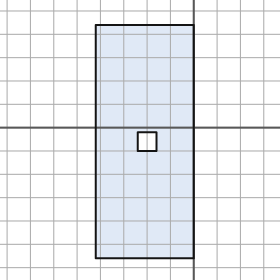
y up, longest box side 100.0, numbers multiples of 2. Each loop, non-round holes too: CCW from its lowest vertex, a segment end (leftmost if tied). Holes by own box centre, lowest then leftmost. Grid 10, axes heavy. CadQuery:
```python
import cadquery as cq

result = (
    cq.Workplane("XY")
    .moveTo(-42.0, -56.0)
    .lineTo(0.0, -56.0)
    .lineTo(0.0, 44.0)
    .lineTo(-42.0, 44.0)
    .close()
    .moveTo(-24.0, -10.0)
    .lineTo(-16.0, -10.0)
    .lineTo(-16.0, -2.0)
    .lineTo(-24.0, -2.0)
    .close()
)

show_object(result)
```